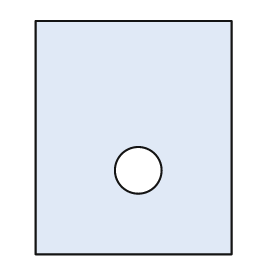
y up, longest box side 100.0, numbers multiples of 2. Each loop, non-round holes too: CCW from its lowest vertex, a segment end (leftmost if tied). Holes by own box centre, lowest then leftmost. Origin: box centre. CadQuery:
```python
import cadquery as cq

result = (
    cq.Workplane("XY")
    .moveTo(-42.0, -50.0)
    .lineTo(42.0, -50.0)
    .lineTo(42.0, 50.0)
    .lineTo(-42.0, 50.0)
    .close()
    .moveTo(2.0, -14.0)
    .circle(10.0)
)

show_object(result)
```